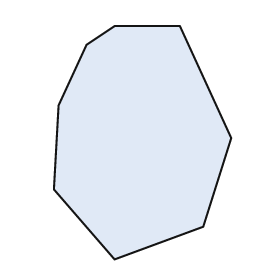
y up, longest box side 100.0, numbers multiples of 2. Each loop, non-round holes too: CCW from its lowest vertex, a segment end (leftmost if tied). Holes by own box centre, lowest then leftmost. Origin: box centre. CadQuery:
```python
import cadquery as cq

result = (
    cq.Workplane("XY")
    .moveTo(-12.0, -50.0)
    .lineTo(26.0, -36.0)
    .lineTo(38.0, 2.0)
    .lineTo(16.0, 50.0)
    .lineTo(-12.0, 50.0)
    .lineTo(-24.0, 42.0)
    .lineTo(-36.0, 16.0)
    .lineTo(-38.0, -20.0)
    .close()
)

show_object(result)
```